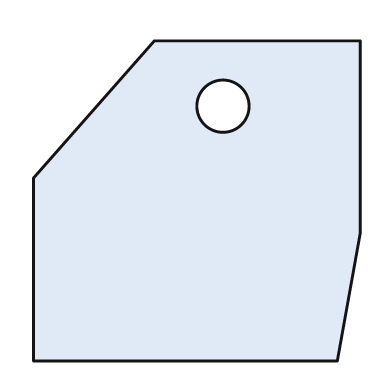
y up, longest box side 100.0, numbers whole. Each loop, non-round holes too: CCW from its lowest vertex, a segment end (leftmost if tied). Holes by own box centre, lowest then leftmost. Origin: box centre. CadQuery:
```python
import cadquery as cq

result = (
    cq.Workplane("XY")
    .moveTo(-50.0, -49.0)
    .lineTo(43.0, -49.0)
    .lineTo(50.0, -10.0)
    .lineTo(50.0, 49.0)
    .lineTo(-13.0, 49.0)
    .lineTo(-50.0, 7.0)
    .close()
    .moveTo(8.0, 29.0)
    .circle(8.0)
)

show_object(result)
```